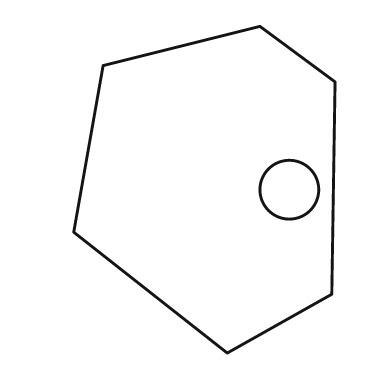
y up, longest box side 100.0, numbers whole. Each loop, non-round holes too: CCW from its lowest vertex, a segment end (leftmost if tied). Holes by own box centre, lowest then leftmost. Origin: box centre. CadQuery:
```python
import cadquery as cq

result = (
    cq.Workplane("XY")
    .moveTo(7.0, -50.0)
    .lineTo(39.0, -32.0)
    .lineTo(40.0, 33.0)
    .lineTo(17.0, 50.0)
    .lineTo(-31.0, 38.0)
    .lineTo(-40.0, -13.0)
    .close()
    .moveTo(26.0, 0.0)
    .circle(9.0)
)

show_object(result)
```